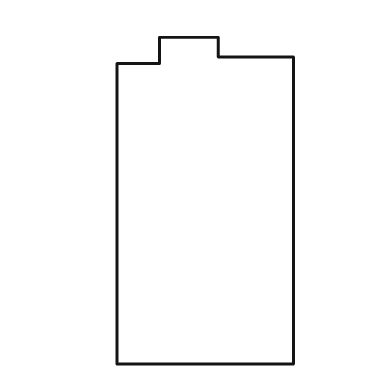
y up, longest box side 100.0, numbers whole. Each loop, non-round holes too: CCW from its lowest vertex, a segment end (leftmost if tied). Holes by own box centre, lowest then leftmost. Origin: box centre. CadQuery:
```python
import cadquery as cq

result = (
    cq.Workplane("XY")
    .moveTo(-27.0, -50.0)
    .lineTo(27.0, -50.0)
    .lineTo(27.0, 44.0)
    .lineTo(4.0, 44.0)
    .lineTo(4.0, 50.0)
    .lineTo(-14.0, 50.0)
    .lineTo(-14.0, 42.0)
    .lineTo(-27.0, 42.0)
    .close()
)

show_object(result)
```